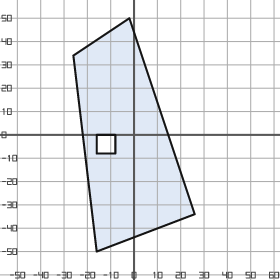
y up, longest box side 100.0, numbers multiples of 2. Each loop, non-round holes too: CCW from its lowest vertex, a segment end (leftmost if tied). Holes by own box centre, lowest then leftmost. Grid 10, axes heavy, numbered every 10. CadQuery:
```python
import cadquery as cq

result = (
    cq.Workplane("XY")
    .moveTo(-16.0, -50.0)
    .lineTo(26.0, -34.0)
    .lineTo(-2.0, 50.0)
    .lineTo(-26.0, 34.0)
    .close()
    .moveTo(-16.0, -8.0)
    .lineTo(-8.0, -8.0)
    .lineTo(-8.0, 0.0)
    .lineTo(-16.0, 0.0)
    .close()
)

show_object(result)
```